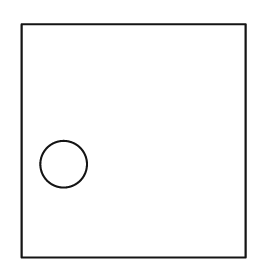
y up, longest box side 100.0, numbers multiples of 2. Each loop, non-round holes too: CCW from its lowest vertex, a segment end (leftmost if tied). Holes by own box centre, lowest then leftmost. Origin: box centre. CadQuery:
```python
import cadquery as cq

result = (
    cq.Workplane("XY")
    .moveTo(-48.0, -50.0)
    .lineTo(48.0, -50.0)
    .lineTo(48.0, 50.0)
    .lineTo(-48.0, 50.0)
    .close()
    .moveTo(-30.0, -10.0)
    .circle(10.0)
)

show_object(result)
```